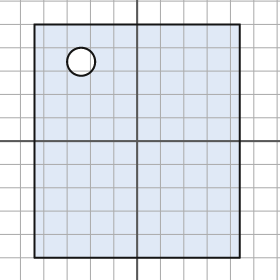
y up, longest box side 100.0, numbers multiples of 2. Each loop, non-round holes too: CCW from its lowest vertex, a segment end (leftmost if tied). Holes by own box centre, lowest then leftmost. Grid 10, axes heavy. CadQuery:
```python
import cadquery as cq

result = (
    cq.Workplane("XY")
    .moveTo(-44.0, -50.0)
    .lineTo(44.0, -50.0)
    .lineTo(44.0, 50.0)
    .lineTo(-44.0, 50.0)
    .close()
    .moveTo(-24.0, 34.0)
    .circle(6.0)
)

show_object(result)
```